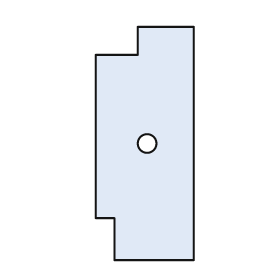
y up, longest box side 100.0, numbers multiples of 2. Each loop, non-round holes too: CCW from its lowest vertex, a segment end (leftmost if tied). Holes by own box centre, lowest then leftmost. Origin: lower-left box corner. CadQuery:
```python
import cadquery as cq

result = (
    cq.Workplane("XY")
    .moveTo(8.0, 0.0)
    .lineTo(42.0, 0.0)
    .lineTo(42.0, 100.0)
    .lineTo(18.0, 100.0)
    .lineTo(18.0, 88.0)
    .lineTo(0.0, 88.0)
    .lineTo(0.0, 18.0)
    .lineTo(8.0, 18.0)
    .close()
    .moveTo(22.0, 50.0)
    .circle(4.0)
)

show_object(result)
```